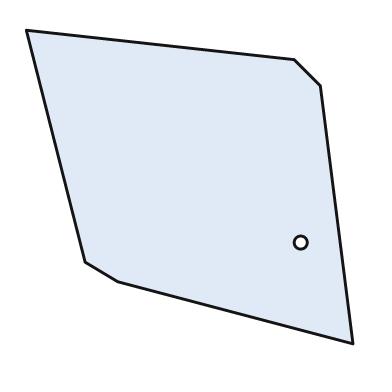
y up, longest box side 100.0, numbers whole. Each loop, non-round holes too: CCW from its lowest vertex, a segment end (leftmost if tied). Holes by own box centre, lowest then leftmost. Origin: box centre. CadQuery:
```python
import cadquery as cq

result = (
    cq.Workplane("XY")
    .moveTo(50.0, -48.0)
    .lineTo(40.0, 31.0)
    .lineTo(32.0, 39.0)
    .lineTo(-50.0, 48.0)
    .lineTo(-32.0, -23.0)
    .lineTo(-22.0, -29.0)
    .close()
    .moveTo(34.0, -17.0)
    .circle(2.0)
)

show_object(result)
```